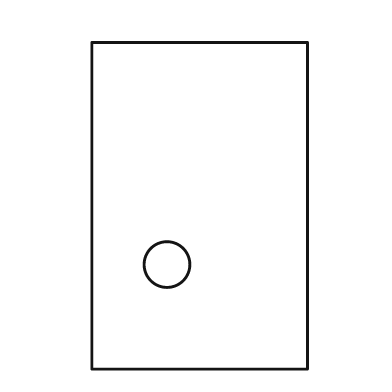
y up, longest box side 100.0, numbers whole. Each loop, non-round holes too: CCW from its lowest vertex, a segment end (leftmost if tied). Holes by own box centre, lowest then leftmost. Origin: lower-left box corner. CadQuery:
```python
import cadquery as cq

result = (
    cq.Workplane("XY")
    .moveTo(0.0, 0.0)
    .lineTo(66.0, 0.0)
    .lineTo(66.0, 100.0)
    .lineTo(0.0, 100.0)
    .close()
    .moveTo(23.0, 32.0)
    .circle(7.0)
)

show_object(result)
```